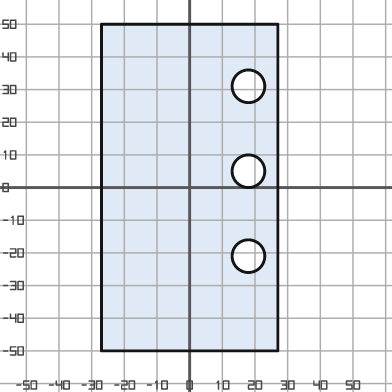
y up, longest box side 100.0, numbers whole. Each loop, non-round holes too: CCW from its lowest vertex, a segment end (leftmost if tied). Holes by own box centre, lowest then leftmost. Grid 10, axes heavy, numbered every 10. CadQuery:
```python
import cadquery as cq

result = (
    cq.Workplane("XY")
    .moveTo(-27.0, -50.0)
    .lineTo(27.0, -50.0)
    .lineTo(27.0, 50.0)
    .lineTo(-27.0, 50.0)
    .close()
    .moveTo(18.0, -21.0)
    .circle(5.0)
    .moveTo(18.0, 5.0)
    .circle(5.0)
    .moveTo(18.0, 31.0)
    .circle(5.0)
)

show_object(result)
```